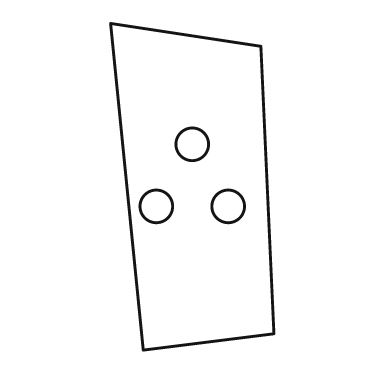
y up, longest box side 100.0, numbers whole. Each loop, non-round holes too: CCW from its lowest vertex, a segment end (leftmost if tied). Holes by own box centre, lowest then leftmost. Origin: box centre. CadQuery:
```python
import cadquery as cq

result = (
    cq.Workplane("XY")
    .moveTo(-15.0, -50.0)
    .lineTo(25.0, -45.0)
    .lineTo(21.0, 43.0)
    .lineTo(-25.0, 50.0)
    .close()
    .moveTo(-11.0, -6.0)
    .circle(5.0)
    .moveTo(11.0, -6.0)
    .circle(5.0)
    .moveTo(0.0, 13.0)
    .circle(5.0)
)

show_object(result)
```